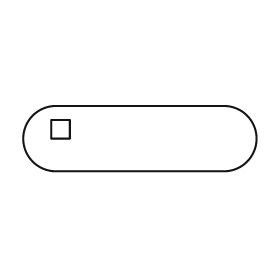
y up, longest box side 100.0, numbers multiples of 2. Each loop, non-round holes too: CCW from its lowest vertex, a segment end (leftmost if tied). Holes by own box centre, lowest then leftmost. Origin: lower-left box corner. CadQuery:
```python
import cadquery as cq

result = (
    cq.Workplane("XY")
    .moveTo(14.0, 0.0)
    .lineTo(86.0, 0.0)
    .threePointArc((100.0, 14.0), (86.0, 28.0))
    .lineTo(14.0, 28.0)
    .threePointArc((0.0, 14.0), (14.0, 0.0))
    .close()
    .moveTo(12.0, 14.0)
    .lineTo(20.0, 14.0)
    .lineTo(20.0, 22.0)
    .lineTo(12.0, 22.0)
    .close()
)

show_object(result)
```